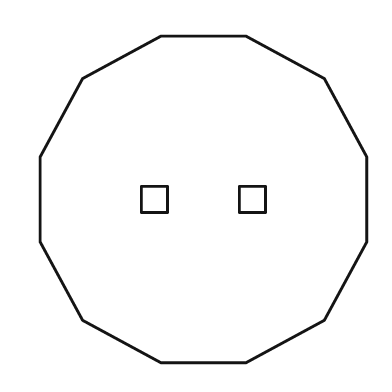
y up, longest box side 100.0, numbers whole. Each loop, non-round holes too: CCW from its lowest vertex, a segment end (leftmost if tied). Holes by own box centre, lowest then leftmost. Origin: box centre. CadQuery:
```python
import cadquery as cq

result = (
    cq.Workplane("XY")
    .moveTo(-13.0, -50.0)
    .lineTo(13.0, -50.0)
    .lineTo(37.0, -37.0)
    .lineTo(50.0, -13.0)
    .lineTo(50.0, 13.0)
    .lineTo(37.0, 37.0)
    .lineTo(13.0, 50.0)
    .lineTo(-13.0, 50.0)
    .lineTo(-37.0, 37.0)
    .lineTo(-50.0, 13.0)
    .lineTo(-50.0, -13.0)
    .lineTo(-37.0, -37.0)
    .close()
    .moveTo(-19.0, -4.0)
    .lineTo(-11.0, -4.0)
    .lineTo(-11.0, 4.0)
    .lineTo(-19.0, 4.0)
    .close()
    .moveTo(11.0, -4.0)
    .lineTo(19.0, -4.0)
    .lineTo(19.0, 4.0)
    .lineTo(11.0, 4.0)
    .close()
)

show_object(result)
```